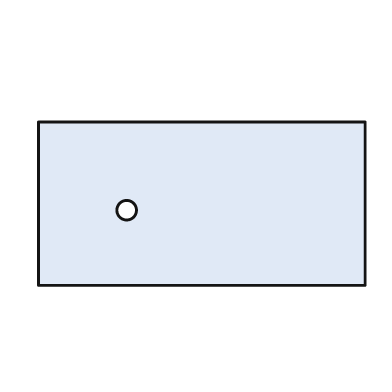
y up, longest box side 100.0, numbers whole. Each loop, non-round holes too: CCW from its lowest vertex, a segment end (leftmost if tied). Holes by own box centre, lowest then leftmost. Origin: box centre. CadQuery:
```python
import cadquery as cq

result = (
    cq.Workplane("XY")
    .moveTo(-50.0, -25.0)
    .lineTo(50.0, -25.0)
    .lineTo(50.0, 25.0)
    .lineTo(-50.0, 25.0)
    .close()
    .moveTo(-23.0, -2.0)
    .circle(3.0)
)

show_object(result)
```